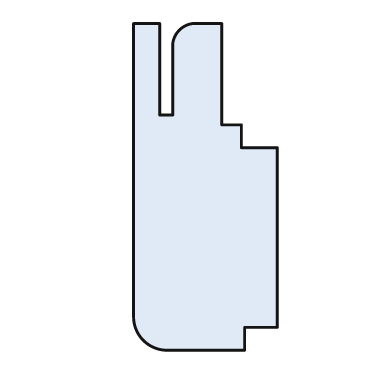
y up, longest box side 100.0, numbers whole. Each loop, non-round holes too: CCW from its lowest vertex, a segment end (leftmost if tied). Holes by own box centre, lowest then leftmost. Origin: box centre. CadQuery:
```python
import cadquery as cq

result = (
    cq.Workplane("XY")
    .moveTo(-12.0, -50.0)
    .lineTo(12.0, -50.0)
    .lineTo(12.0, -43.0)
    .lineTo(22.0, -43.0)
    .lineTo(22.0, 12.0)
    .lineTo(11.0, 12.0)
    .lineTo(11.0, 19.0)
    .lineTo(5.0, 19.0)
    .lineTo(5.0, 50.0)
    .lineTo(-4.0, 50.0)
    .threePointArc((-8.0, 48.0), (-10.0, 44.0))
    .lineTo(-10.0, 22.0)
    .lineTo(-14.0, 22.0)
    .lineTo(-14.0, 50.0)
    .lineTo(-22.0, 50.0)
    .lineTo(-22.0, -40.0)
    .threePointArc((-19.0, -47.0), (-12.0, -50.0))
    .close()
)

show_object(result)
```